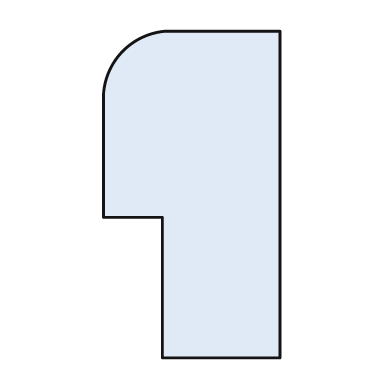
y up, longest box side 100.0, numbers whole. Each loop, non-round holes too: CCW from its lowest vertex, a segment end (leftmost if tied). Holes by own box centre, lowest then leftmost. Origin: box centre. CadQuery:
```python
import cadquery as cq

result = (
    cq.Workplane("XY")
    .moveTo(-9.0, -50.0)
    .lineTo(27.0, -50.0)
    .lineTo(27.0, 50.0)
    .lineTo(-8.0, 50.0)
    .threePointArc((-21.0, 44.0), (-27.0, 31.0))
    .lineTo(-27.0, -7.0)
    .lineTo(-9.0, -7.0)
    .close()
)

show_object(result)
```